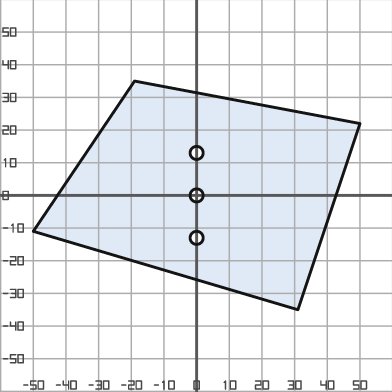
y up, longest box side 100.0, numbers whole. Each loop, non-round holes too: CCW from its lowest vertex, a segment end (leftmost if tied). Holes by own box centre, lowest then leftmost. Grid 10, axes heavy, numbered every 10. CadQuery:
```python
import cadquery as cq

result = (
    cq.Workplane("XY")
    .moveTo(31.0, -35.0)
    .lineTo(50.0, 22.0)
    .lineTo(-19.0, 35.0)
    .lineTo(-50.0, -11.0)
    .close()
    .moveTo(0.0, -13.0)
    .circle(2.0)
    .moveTo(0.0, 0.0)
    .circle(2.0)
    .moveTo(0.0, 13.0)
    .circle(2.0)
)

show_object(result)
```